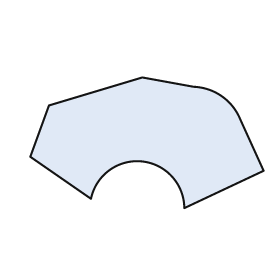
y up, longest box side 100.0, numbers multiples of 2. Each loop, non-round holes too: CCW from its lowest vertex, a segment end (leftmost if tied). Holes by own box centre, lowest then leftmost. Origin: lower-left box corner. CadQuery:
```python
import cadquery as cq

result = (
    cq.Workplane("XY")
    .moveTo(66.0, 0.0)
    .lineTo(100.0, 16.0)
    .lineTo(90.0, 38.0)
    .threePointArc((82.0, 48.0), (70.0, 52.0))
    .lineTo(48.0, 56.0)
    .lineTo(8.0, 44.0)
    .lineTo(0.0, 22.0)
    .lineTo(26.0, 4.0)
    .threePointArc((48.0, 20.0), (66.0, 0.0))
    .close()
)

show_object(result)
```